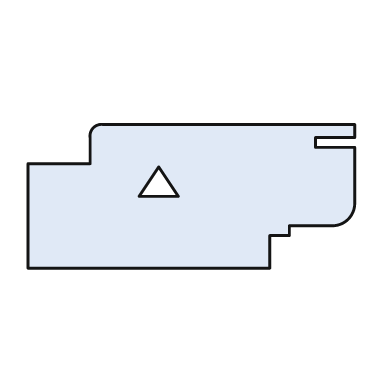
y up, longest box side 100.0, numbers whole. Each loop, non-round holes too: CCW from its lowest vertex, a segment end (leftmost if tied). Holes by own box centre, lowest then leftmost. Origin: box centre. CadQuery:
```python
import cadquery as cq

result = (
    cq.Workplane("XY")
    .moveTo(-50.0, -22.0)
    .lineTo(24.0, -22.0)
    .lineTo(24.0, -12.0)
    .lineTo(30.0, -12.0)
    .lineTo(30.0, -9.0)
    .lineTo(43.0, -9.0)
    .threePointArc((48.0, -7.0), (50.0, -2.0))
    .lineTo(50.0, 15.0)
    .lineTo(38.0, 15.0)
    .lineTo(38.0, 18.0)
    .lineTo(50.0, 18.0)
    .lineTo(50.0, 22.0)
    .lineTo(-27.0, 22.0)
    .threePointArc((-30.0, 21.0), (-31.0, 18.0))
    .lineTo(-31.0, 10.0)
    .lineTo(-50.0, 10.0)
    .close()
    .moveTo(-16.0, 0.0)
    .lineTo(-4.0, 0.0)
    .lineTo(-10.0, 9.0)
    .close()
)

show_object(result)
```